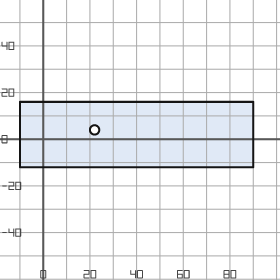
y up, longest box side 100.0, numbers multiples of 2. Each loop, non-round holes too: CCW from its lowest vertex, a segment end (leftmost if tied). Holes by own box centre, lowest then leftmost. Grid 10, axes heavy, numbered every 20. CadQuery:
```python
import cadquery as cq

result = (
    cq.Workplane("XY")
    .moveTo(-10.0, -12.0)
    .lineTo(90.0, -12.0)
    .lineTo(90.0, 16.0)
    .lineTo(-10.0, 16.0)
    .close()
    .moveTo(22.0, 4.0)
    .circle(2.0)
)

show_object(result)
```